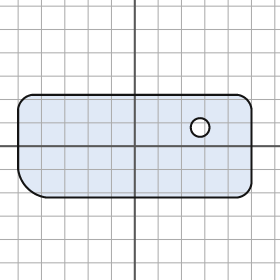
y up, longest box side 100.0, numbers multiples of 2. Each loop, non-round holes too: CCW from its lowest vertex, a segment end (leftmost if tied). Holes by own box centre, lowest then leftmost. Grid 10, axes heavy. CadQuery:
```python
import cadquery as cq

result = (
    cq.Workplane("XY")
    .moveTo(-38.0, -22.0)
    .lineTo(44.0, -22.0)
    .threePointArc((48.0, -20.0), (50.0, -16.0))
    .lineTo(50.0, 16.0)
    .threePointArc((48.0, 20.0), (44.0, 22.0))
    .lineTo(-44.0, 22.0)
    .threePointArc((-48.0, 20.0), (-50.0, 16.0))
    .lineTo(-50.0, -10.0)
    .threePointArc((-46.0, -18.0), (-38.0, -22.0))
    .close()
    .moveTo(28.0, 8.0)
    .circle(4.0)
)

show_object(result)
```